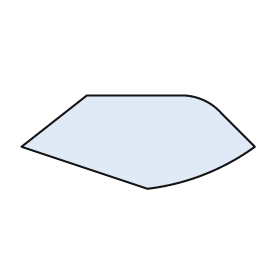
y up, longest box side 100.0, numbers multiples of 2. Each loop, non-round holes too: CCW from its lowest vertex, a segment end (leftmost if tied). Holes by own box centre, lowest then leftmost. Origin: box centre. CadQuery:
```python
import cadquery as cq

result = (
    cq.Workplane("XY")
    .moveTo(4.0, -20.0)
    .threePointArc((28.0, -14.0), (50.0, -2.0))
    .lineTo(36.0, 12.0)
    .threePointArc((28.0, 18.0), (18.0, 20.0))
    .lineTo(-22.0, 20.0)
    .lineTo(-50.0, -2.0)
    .close()
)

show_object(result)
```